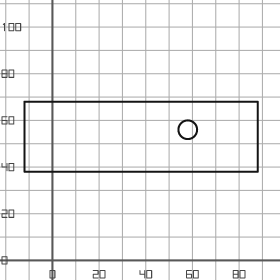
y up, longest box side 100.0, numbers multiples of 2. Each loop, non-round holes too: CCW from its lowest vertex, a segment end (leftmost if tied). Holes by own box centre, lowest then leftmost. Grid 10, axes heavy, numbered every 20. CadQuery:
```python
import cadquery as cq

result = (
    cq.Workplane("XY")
    .moveTo(-12.0, 38.0)
    .lineTo(88.0, 38.0)
    .lineTo(88.0, 68.0)
    .lineTo(-12.0, 68.0)
    .close()
    .moveTo(58.0, 56.0)
    .circle(4.0)
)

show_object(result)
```